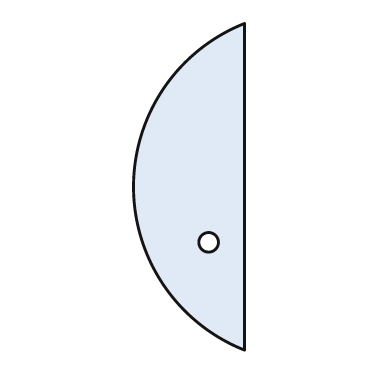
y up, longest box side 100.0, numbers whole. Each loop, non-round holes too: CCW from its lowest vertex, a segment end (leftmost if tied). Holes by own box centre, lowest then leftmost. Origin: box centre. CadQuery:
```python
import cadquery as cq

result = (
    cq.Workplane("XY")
    .moveTo(17.0, -50.0)
    .lineTo(17.0, 50.0)
    .threePointArc((-17.0, 0.0), (17.0, -50.0))
    .close()
    .moveTo(6.0, -17.0)
    .circle(3.0)
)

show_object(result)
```